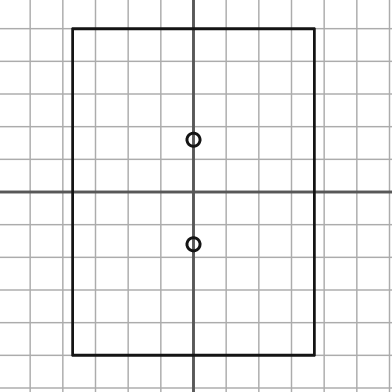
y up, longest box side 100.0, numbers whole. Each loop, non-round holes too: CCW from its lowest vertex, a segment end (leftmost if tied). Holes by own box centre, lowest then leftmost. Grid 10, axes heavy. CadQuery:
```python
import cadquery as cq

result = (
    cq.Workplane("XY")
    .moveTo(-37.0, -50.0)
    .lineTo(37.0, -50.0)
    .lineTo(37.0, 50.0)
    .lineTo(-37.0, 50.0)
    .close()
    .moveTo(0.0, -16.0)
    .circle(2.0)
    .moveTo(0.0, 16.0)
    .circle(2.0)
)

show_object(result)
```